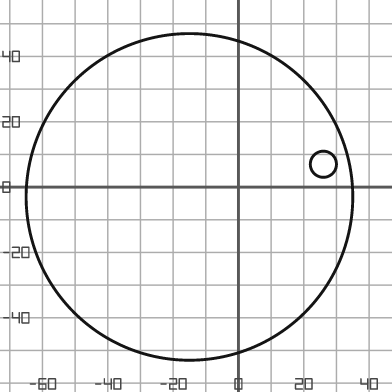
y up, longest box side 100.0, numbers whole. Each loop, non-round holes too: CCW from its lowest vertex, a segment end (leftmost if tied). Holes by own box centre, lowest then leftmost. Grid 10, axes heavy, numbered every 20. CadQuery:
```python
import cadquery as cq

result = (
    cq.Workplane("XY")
    .moveTo(-15.0, -3.0)
    .circle(50.0)
    .moveTo(26.0, 7.0)
    .circle(4.0)
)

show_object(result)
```